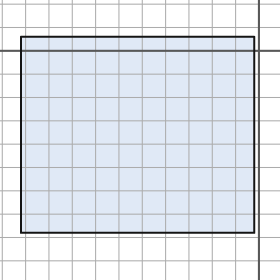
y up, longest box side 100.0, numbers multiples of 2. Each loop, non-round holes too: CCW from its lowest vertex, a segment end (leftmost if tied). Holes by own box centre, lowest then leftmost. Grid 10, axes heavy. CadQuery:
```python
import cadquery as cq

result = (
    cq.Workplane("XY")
    .moveTo(-102.0, -78.0)
    .lineTo(-2.0, -78.0)
    .lineTo(-2.0, 6.0)
    .lineTo(-102.0, 6.0)
    .close()
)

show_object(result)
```